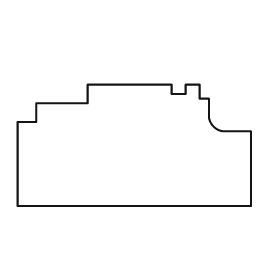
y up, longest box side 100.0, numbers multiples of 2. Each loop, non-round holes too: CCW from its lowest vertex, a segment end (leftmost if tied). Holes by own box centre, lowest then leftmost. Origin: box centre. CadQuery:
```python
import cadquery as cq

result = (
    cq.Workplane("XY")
    .moveTo(-50.0, -26.0)
    .lineTo(50.0, -26.0)
    .lineTo(50.0, 6.0)
    .lineTo(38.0, 6.0)
    .threePointArc((34.0, 8.0), (32.0, 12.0))
    .lineTo(32.0, 20.0)
    .lineTo(28.0, 20.0)
    .lineTo(28.0, 26.0)
    .lineTo(22.0, 26.0)
    .lineTo(22.0, 22.0)
    .lineTo(16.0, 22.0)
    .lineTo(16.0, 26.0)
    .lineTo(-20.0, 26.0)
    .lineTo(-20.0, 18.0)
    .lineTo(-42.0, 18.0)
    .lineTo(-42.0, 10.0)
    .lineTo(-50.0, 10.0)
    .close()
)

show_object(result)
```